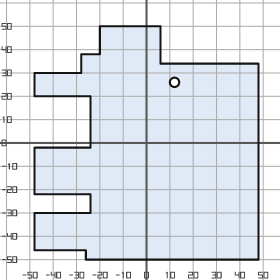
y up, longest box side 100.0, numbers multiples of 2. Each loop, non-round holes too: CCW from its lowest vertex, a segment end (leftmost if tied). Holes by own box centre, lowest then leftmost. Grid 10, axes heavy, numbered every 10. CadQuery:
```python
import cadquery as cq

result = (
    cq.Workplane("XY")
    .moveTo(-26.0, -50.0)
    .lineTo(48.0, -50.0)
    .lineTo(48.0, 34.0)
    .lineTo(6.0, 34.0)
    .lineTo(6.0, 50.0)
    .lineTo(-20.0, 50.0)
    .lineTo(-20.0, 38.0)
    .lineTo(-28.0, 38.0)
    .lineTo(-28.0, 30.0)
    .lineTo(-48.0, 30.0)
    .lineTo(-48.0, 20.0)
    .lineTo(-24.0, 20.0)
    .lineTo(-24.0, -2.0)
    .lineTo(-48.0, -2.0)
    .lineTo(-48.0, -22.0)
    .lineTo(-24.0, -22.0)
    .lineTo(-24.0, -30.0)
    .lineTo(-48.0, -30.0)
    .lineTo(-48.0, -46.0)
    .lineTo(-26.0, -46.0)
    .close()
    .moveTo(12.0, 26.0)
    .circle(2.0)
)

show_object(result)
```